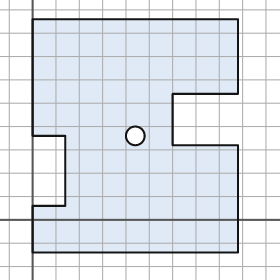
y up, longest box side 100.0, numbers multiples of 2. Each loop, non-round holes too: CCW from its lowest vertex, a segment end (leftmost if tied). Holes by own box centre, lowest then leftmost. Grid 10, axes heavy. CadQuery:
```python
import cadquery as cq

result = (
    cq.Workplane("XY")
    .moveTo(0.0, -14.0)
    .lineTo(88.0, -14.0)
    .lineTo(88.0, 32.0)
    .lineTo(60.0, 32.0)
    .lineTo(60.0, 54.0)
    .lineTo(88.0, 54.0)
    .lineTo(88.0, 86.0)
    .lineTo(0.0, 86.0)
    .lineTo(0.0, 36.0)
    .lineTo(14.0, 36.0)
    .lineTo(14.0, 6.0)
    .lineTo(0.0, 6.0)
    .close()
    .moveTo(44.0, 36.0)
    .circle(4.0)
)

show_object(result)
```